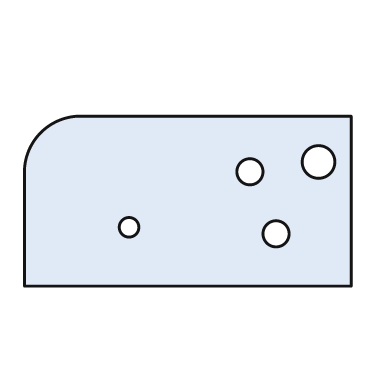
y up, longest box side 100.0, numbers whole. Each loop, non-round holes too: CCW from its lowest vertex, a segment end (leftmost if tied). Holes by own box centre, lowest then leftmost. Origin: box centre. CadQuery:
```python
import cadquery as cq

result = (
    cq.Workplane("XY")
    .moveTo(-50.0, -26.0)
    .lineTo(50.0, -26.0)
    .lineTo(50.0, 26.0)
    .lineTo(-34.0, 26.0)
    .threePointArc((-45.0, 21.0), (-50.0, 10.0))
    .close()
    .moveTo(27.0, -10.0)
    .circle(4.0)
    .moveTo(-18.0, -8.0)
    .circle(3.0)
    .moveTo(19.0, 9.0)
    .circle(4.0)
    .moveTo(40.0, 12.0)
    .circle(5.0)
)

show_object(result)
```